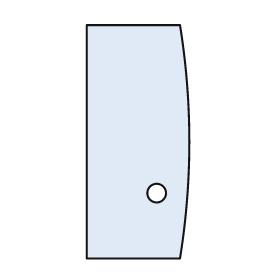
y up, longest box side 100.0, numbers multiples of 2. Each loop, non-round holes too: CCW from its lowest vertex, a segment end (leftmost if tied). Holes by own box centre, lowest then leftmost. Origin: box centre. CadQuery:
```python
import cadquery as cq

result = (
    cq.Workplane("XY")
    .moveTo(-22.0, -50.0)
    .lineTo(18.0, -50.0)
    .threePointArc((22.0, 0.0), (18.0, 50.0))
    .lineTo(-22.0, 50.0)
    .close()
    .moveTo(8.0, -22.0)
    .circle(4.0)
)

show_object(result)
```